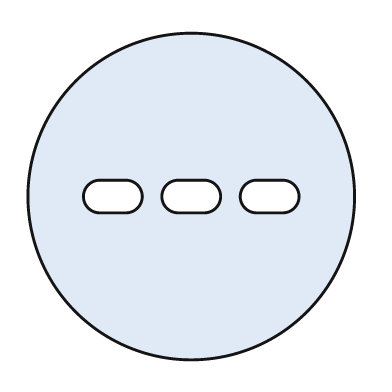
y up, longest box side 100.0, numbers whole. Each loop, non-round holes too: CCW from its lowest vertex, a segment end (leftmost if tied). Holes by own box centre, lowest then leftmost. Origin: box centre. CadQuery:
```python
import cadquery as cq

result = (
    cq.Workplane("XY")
    .moveTo(0.0, 0.0)
    .circle(50.0)
    .moveTo(-28.0, -5.0)
    .lineTo(-20.0, -5.0)
    .threePointArc((-15.0, 0.0), (-20.0, 5.0))
    .lineTo(-28.0, 5.0)
    .threePointArc((-33.0, 0.0), (-28.0, -5.0))
    .close()
    .moveTo(-4.0, -5.0)
    .lineTo(4.0, -5.0)
    .threePointArc((9.0, 0.0), (4.0, 5.0))
    .lineTo(-4.0, 5.0)
    .threePointArc((-9.0, 0.0), (-4.0, -5.0))
    .close()
    .moveTo(20.0, -5.0)
    .lineTo(28.0, -5.0)
    .threePointArc((33.0, 0.0), (28.0, 5.0))
    .lineTo(20.0, 5.0)
    .threePointArc((15.0, 0.0), (20.0, -5.0))
    .close()
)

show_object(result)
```